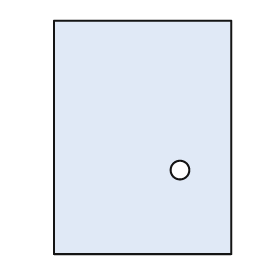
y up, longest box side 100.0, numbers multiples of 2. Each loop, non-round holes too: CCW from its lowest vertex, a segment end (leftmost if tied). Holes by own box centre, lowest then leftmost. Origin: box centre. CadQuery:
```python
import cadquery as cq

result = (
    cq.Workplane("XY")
    .moveTo(-38.0, -50.0)
    .lineTo(38.0, -50.0)
    .lineTo(38.0, 50.0)
    .lineTo(-38.0, 50.0)
    .close()
    .moveTo(16.0, -14.0)
    .circle(4.0)
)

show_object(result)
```